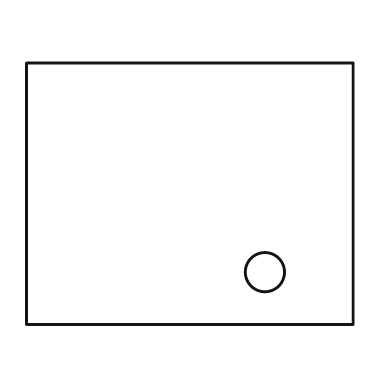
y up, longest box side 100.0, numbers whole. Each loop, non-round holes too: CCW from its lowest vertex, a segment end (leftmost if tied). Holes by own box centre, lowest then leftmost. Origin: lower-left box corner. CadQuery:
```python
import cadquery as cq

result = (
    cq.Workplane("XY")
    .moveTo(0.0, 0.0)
    .lineTo(100.0, 0.0)
    .lineTo(100.0, 80.0)
    .lineTo(0.0, 80.0)
    .close()
    .moveTo(73.0, 16.0)
    .circle(6.0)
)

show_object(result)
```